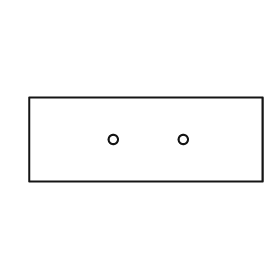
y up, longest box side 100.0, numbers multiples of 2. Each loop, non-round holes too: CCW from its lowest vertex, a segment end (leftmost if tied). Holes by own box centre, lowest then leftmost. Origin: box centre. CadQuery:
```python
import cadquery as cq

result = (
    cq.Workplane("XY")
    .moveTo(-50.0, -18.0)
    .lineTo(50.0, -18.0)
    .lineTo(50.0, 18.0)
    .lineTo(-50.0, 18.0)
    .close()
    .moveTo(-14.0, 0.0)
    .circle(2.0)
    .moveTo(16.0, 0.0)
    .circle(2.0)
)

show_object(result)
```